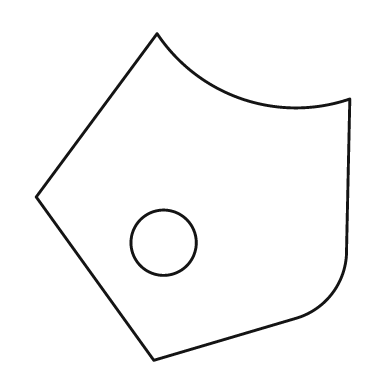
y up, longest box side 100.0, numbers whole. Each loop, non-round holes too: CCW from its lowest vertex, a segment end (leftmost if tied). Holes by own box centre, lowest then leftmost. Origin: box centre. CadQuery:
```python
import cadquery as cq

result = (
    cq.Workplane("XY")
    .moveTo(-12.0, -50.0)
    .lineTo(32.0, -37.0)
    .threePointArc((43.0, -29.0), (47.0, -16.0))
    .lineTo(48.0, 30.0)
    .threePointArc((15.0, 30.0), (-11.0, 50.0))
    .lineTo(-48.0, 0.0)
    .close()
    .moveTo(-9.0, -14.0)
    .circle(10.0)
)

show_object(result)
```